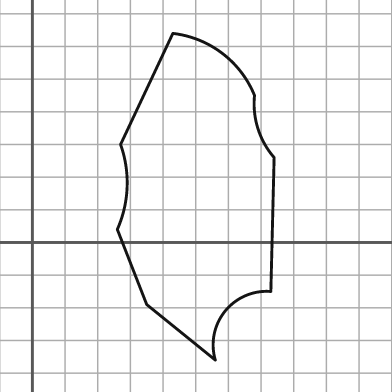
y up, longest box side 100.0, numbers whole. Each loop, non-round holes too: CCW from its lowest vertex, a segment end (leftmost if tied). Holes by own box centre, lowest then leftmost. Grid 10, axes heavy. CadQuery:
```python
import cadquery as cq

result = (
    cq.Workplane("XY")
    .moveTo(56.0, -36.0)
    .threePointArc((59.0, -21.0), (73.0, -15.0))
    .lineTo(74.0, 26.0)
    .threePointArc((69.0, 35.0), (68.0, 45.0))
    .threePointArc((58.0, 58.0), (43.0, 64.0))
    .lineTo(27.0, 30.0)
    .threePointArc((29.0, 17.0), (26.0, 4.0))
    .lineTo(35.0, -19.0)
    .close()
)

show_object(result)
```